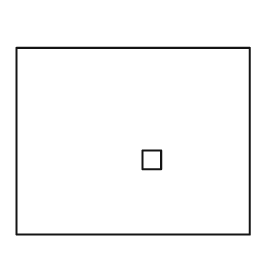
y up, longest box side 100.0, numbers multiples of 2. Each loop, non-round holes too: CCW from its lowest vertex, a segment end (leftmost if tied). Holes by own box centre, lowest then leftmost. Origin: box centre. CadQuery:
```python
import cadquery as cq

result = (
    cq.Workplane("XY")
    .moveTo(-50.0, -40.0)
    .lineTo(50.0, -40.0)
    .lineTo(50.0, 40.0)
    .lineTo(-50.0, 40.0)
    .close()
    .moveTo(4.0, -12.0)
    .lineTo(12.0, -12.0)
    .lineTo(12.0, -4.0)
    .lineTo(4.0, -4.0)
    .close()
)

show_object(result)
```